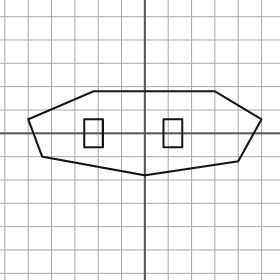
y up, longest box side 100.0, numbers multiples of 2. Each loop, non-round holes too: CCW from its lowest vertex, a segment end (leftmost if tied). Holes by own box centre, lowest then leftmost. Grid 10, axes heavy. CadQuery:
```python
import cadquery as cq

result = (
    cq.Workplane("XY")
    .moveTo(0.0, -18.0)
    .lineTo(40.0, -12.0)
    .lineTo(50.0, 6.0)
    .lineTo(30.0, 18.0)
    .lineTo(-22.0, 18.0)
    .lineTo(-50.0, 6.0)
    .lineTo(-44.0, -10.0)
    .close()
    .moveTo(-26.0, -6.0)
    .lineTo(-18.0, -6.0)
    .lineTo(-18.0, 6.0)
    .lineTo(-26.0, 6.0)
    .close()
    .moveTo(8.0, -6.0)
    .lineTo(16.0, -6.0)
    .lineTo(16.0, 6.0)
    .lineTo(8.0, 6.0)
    .close()
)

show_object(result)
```